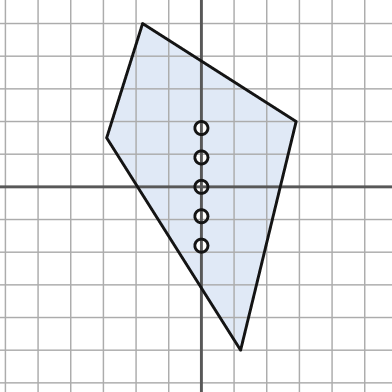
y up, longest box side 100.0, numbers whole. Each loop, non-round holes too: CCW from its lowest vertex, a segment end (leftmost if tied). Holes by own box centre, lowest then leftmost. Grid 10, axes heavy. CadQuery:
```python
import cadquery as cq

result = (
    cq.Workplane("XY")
    .moveTo(12.0, -50.0)
    .lineTo(29.0, 20.0)
    .lineTo(-18.0, 50.0)
    .lineTo(-29.0, 15.0)
    .close()
    .moveTo(0.0, -18.0)
    .circle(2.0)
    .moveTo(0.0, -9.0)
    .circle(2.0)
    .moveTo(0.0, 0.0)
    .circle(2.0)
    .moveTo(0.0, 9.0)
    .circle(2.0)
    .moveTo(0.0, 18.0)
    .circle(2.0)
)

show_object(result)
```